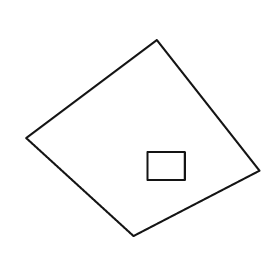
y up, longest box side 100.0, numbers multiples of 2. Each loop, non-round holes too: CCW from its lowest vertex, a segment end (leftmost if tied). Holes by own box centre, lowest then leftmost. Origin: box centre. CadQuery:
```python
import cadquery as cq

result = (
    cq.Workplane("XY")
    .moveTo(-4.0, -42.0)
    .lineTo(50.0, -14.0)
    .lineTo(6.0, 42.0)
    .lineTo(-50.0, 0.0)
    .close()
    .moveTo(2.0, -18.0)
    .lineTo(18.0, -18.0)
    .lineTo(18.0, -6.0)
    .lineTo(2.0, -6.0)
    .close()
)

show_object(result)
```